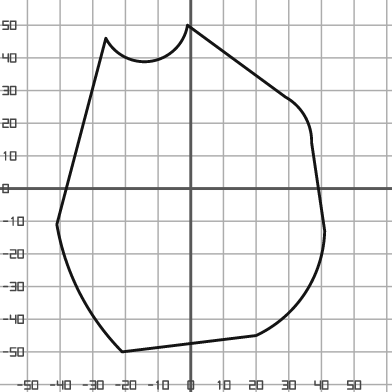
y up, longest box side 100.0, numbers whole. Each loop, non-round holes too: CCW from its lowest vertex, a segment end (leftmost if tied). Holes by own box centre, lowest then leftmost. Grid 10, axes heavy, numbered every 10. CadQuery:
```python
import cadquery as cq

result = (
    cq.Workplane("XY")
    .moveTo(-21.0, -50.0)
    .lineTo(20.0, -45.0)
    .threePointArc((35.0, -32.0), (41.0, -13.0))
    .lineTo(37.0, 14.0)
    .threePointArc((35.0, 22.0), (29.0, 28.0))
    .lineTo(-1.0, 50.0)
    .threePointArc((-12.0, 39.0), (-26.0, 46.0))
    .lineTo(-41.0, -11.0)
    .threePointArc((-34.0, -32.0), (-21.0, -50.0))
    .close()
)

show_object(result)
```